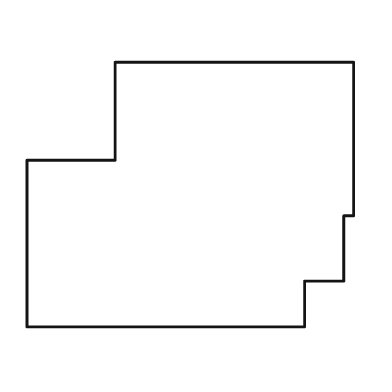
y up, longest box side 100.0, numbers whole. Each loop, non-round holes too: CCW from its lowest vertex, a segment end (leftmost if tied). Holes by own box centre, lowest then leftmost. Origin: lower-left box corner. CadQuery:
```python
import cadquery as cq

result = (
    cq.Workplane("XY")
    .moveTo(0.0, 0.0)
    .lineTo(85.0, 0.0)
    .lineTo(85.0, 14.0)
    .lineTo(97.0, 14.0)
    .lineTo(97.0, 34.0)
    .lineTo(100.0, 34.0)
    .lineTo(100.0, 81.0)
    .lineTo(27.0, 81.0)
    .lineTo(27.0, 51.0)
    .lineTo(0.0, 51.0)
    .close()
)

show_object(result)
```